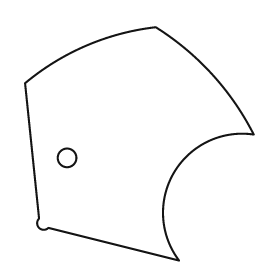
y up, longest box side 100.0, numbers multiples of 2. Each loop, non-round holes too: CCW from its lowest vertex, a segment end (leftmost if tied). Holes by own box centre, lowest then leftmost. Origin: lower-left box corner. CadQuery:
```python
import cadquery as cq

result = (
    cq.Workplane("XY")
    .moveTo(66.0, 0.0)
    .threePointArc((64.0, 38.0), (98.0, 54.0))
    .threePointArc((80.0, 80.0), (56.0, 100.0))
    .threePointArc((26.0, 92.0), (0.0, 76.0))
    .lineTo(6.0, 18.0)
    .threePointArc((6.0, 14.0), (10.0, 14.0))
    .close()
    .moveTo(18.0, 44.0)
    .circle(4.0)
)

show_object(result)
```